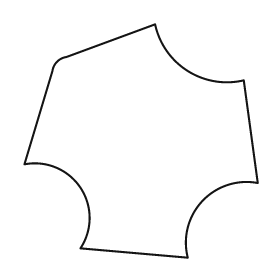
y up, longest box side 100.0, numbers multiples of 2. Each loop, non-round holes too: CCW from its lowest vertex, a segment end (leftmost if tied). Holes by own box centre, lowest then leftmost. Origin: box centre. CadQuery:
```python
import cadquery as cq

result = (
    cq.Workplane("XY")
    .moveTo(20.0, -50.0)
    .threePointArc((26.0, -26.0), (50.0, -18.0))
    .lineTo(44.0, 26.0)
    .threePointArc((20.0, 30.0), (6.0, 50.0))
    .lineTo(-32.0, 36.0)
    .threePointArc((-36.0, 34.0), (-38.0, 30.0))
    .lineTo(-50.0, -10.0)
    .threePointArc((-26.0, -20.0), (-26.0, -46.0))
    .close()
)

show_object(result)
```